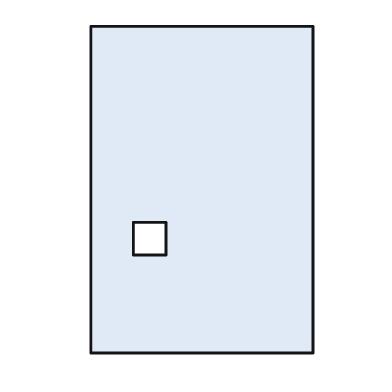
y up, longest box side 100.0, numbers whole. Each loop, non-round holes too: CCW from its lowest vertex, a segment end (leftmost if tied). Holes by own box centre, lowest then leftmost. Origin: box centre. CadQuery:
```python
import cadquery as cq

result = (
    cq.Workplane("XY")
    .moveTo(-34.0, -50.0)
    .lineTo(34.0, -50.0)
    .lineTo(34.0, 50.0)
    .lineTo(-34.0, 50.0)
    .close()
    .moveTo(-21.0, -20.0)
    .lineTo(-11.0, -20.0)
    .lineTo(-11.0, -10.0)
    .lineTo(-21.0, -10.0)
    .close()
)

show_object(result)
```